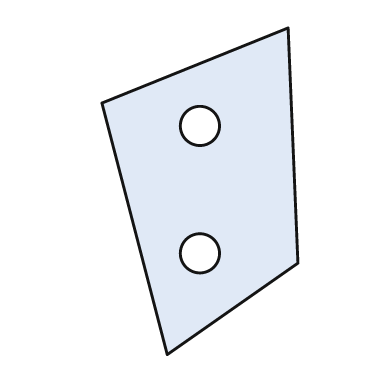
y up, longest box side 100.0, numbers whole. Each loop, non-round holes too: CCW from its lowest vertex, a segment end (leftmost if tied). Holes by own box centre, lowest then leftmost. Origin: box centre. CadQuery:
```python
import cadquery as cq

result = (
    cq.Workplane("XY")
    .moveTo(-10.0, -50.0)
    .lineTo(30.0, -22.0)
    .lineTo(27.0, 50.0)
    .lineTo(-30.0, 27.0)
    .close()
    .moveTo(0.0, -19.0)
    .circle(6.0)
    .moveTo(0.0, 20.0)
    .circle(6.0)
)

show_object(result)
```